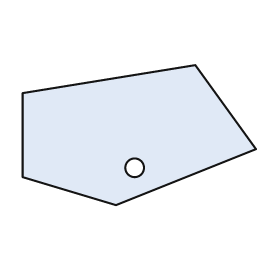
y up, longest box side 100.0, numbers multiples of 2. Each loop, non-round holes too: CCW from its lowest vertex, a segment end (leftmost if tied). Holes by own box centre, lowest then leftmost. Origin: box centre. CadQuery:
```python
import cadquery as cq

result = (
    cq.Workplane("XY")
    .moveTo(-10.0, -30.0)
    .lineTo(50.0, -6.0)
    .lineTo(24.0, 30.0)
    .lineTo(-50.0, 18.0)
    .lineTo(-50.0, -18.0)
    .close()
    .moveTo(-2.0, -14.0)
    .circle(4.0)
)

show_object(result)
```